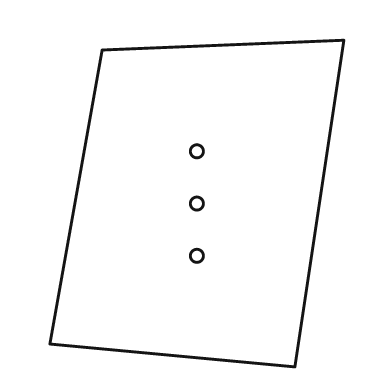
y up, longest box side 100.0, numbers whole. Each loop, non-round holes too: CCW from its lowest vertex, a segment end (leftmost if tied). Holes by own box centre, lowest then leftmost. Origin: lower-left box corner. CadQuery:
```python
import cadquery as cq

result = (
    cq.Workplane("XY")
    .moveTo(75.0, 0.0)
    .lineTo(90.0, 100.0)
    .lineTo(16.0, 97.0)
    .lineTo(0.0, 7.0)
    .close()
    .moveTo(45.0, 34.0)
    .circle(2.0)
    .moveTo(45.0, 50.0)
    .circle(2.0)
    .moveTo(45.0, 66.0)
    .circle(2.0)
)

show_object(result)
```